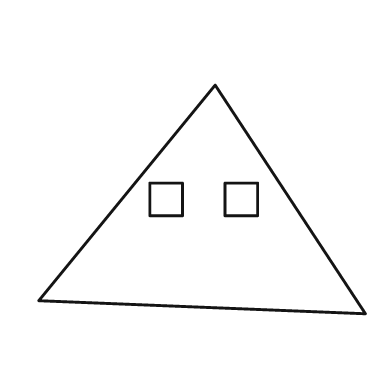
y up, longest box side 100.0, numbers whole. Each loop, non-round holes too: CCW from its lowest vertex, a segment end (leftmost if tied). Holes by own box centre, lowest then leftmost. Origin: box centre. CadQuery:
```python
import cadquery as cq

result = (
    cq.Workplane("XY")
    .moveTo(50.0, -35.0)
    .lineTo(4.0, 35.0)
    .lineTo(-50.0, -31.0)
    .close()
    .moveTo(-16.0, -5.0)
    .lineTo(-6.0, -5.0)
    .lineTo(-6.0, 5.0)
    .lineTo(-16.0, 5.0)
    .close()
    .moveTo(7.0, -5.0)
    .lineTo(17.0, -5.0)
    .lineTo(17.0, 5.0)
    .lineTo(7.0, 5.0)
    .close()
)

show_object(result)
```